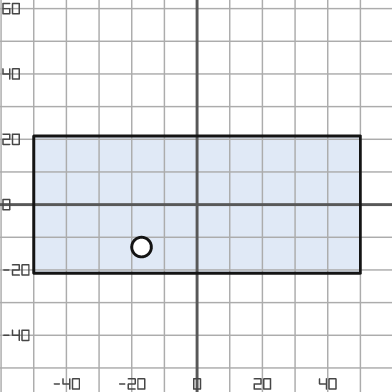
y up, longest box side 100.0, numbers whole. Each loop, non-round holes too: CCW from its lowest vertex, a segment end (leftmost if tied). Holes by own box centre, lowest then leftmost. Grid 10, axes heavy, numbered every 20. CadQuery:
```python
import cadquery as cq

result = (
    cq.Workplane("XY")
    .moveTo(-50.0, -21.0)
    .lineTo(50.0, -21.0)
    .lineTo(50.0, 21.0)
    .lineTo(-50.0, 21.0)
    .close()
    .moveTo(-17.0, -13.0)
    .circle(3.0)
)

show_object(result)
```